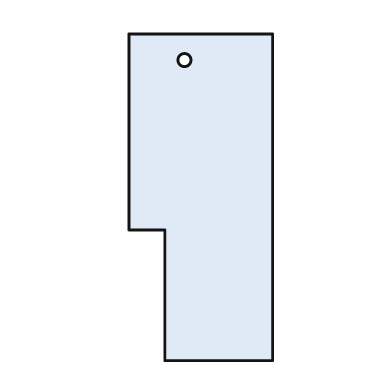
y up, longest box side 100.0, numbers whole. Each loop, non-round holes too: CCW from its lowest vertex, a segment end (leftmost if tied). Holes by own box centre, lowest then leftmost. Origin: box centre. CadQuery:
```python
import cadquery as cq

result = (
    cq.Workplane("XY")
    .moveTo(-11.0, -50.0)
    .lineTo(22.0, -50.0)
    .lineTo(22.0, 50.0)
    .lineTo(-22.0, 50.0)
    .lineTo(-22.0, -10.0)
    .lineTo(-11.0, -10.0)
    .close()
    .moveTo(-5.0, 42.0)
    .circle(2.0)
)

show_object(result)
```